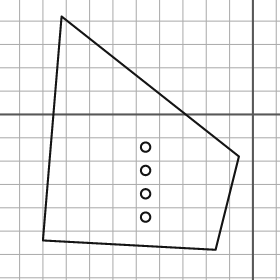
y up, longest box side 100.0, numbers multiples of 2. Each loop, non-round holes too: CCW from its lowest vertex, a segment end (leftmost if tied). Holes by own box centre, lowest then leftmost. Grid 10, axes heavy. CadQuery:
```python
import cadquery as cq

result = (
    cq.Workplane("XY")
    .moveTo(-16.0, -58.0)
    .lineTo(-6.0, -18.0)
    .lineTo(-82.0, 42.0)
    .lineTo(-90.0, -54.0)
    .close()
    .moveTo(-46.0, -44.0)
    .circle(2.0)
    .moveTo(-46.0, -34.0)
    .circle(2.0)
    .moveTo(-46.0, -24.0)
    .circle(2.0)
    .moveTo(-46.0, -14.0)
    .circle(2.0)
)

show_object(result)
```